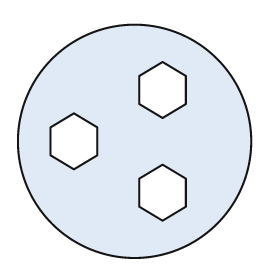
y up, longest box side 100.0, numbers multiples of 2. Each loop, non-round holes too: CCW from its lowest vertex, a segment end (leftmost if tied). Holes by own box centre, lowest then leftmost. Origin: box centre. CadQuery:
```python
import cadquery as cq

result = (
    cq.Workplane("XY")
    .moveTo(0.0, 0.0)
    .circle(50.0)
    .moveTo(12.0, -34.0)
    .lineTo(22.0, -28.0)
    .lineTo(22.0, -16.0)
    .lineTo(12.0, -10.0)
    .lineTo(2.0, -16.0)
    .lineTo(2.0, -28.0)
    .close()
    .moveTo(-26.0, -12.0)
    .lineTo(-16.0, -6.0)
    .lineTo(-16.0, 6.0)
    .lineTo(-26.0, 12.0)
    .lineTo(-36.0, 6.0)
    .lineTo(-36.0, -6.0)
    .close()
    .moveTo(12.0, 10.0)
    .lineTo(22.0, 16.0)
    .lineTo(22.0, 28.0)
    .lineTo(12.0, 34.0)
    .lineTo(2.0, 28.0)
    .lineTo(2.0, 16.0)
    .close()
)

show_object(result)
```